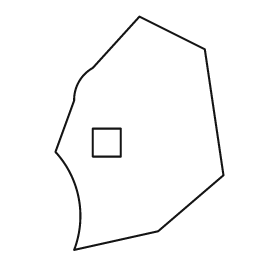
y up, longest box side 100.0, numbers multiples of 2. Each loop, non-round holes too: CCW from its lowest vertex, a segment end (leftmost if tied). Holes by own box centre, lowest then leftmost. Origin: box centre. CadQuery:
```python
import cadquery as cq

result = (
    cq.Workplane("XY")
    .moveTo(-28.0, -50.0)
    .lineTo(8.0, -42.0)
    .lineTo(36.0, -18.0)
    .lineTo(28.0, 36.0)
    .lineTo(0.0, 50.0)
    .lineTo(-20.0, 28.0)
    .threePointArc((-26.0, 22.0), (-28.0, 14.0))
    .lineTo(-36.0, -8.0)
    .threePointArc((-26.0, -28.0), (-28.0, -50.0))
    .close()
    .moveTo(-20.0, -10.0)
    .lineTo(-8.0, -10.0)
    .lineTo(-8.0, 2.0)
    .lineTo(-20.0, 2.0)
    .close()
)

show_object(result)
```